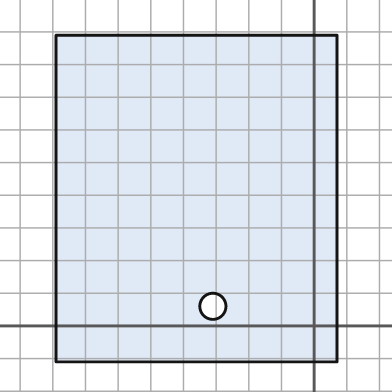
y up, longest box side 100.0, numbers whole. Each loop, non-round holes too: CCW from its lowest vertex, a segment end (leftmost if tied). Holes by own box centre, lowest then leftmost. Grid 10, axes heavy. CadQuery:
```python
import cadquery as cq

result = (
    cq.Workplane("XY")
    .moveTo(-79.0, -11.0)
    .lineTo(7.0, -11.0)
    .lineTo(7.0, 89.0)
    .lineTo(-79.0, 89.0)
    .close()
    .moveTo(-31.0, 6.0)
    .circle(4.0)
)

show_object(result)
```